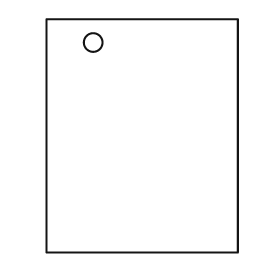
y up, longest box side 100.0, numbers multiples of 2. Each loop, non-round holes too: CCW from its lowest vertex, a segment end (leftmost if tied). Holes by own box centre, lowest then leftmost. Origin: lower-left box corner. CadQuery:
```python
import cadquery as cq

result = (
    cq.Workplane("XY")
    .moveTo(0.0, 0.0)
    .lineTo(82.0, 0.0)
    .lineTo(82.0, 100.0)
    .lineTo(0.0, 100.0)
    .close()
    .moveTo(20.0, 90.0)
    .circle(4.0)
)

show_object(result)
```